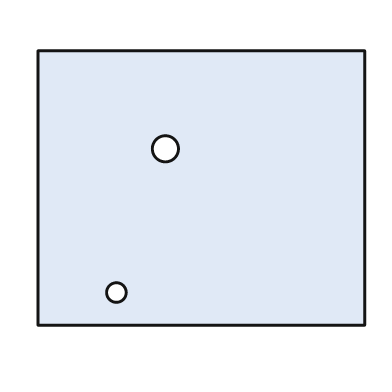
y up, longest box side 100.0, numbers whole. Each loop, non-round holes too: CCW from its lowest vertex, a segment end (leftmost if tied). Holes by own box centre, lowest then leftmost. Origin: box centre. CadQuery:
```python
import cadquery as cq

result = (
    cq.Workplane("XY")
    .moveTo(-50.0, -42.0)
    .lineTo(50.0, -42.0)
    .lineTo(50.0, 42.0)
    .lineTo(-50.0, 42.0)
    .close()
    .moveTo(-26.0, -32.0)
    .circle(3.0)
    .moveTo(-11.0, 12.0)
    .circle(4.0)
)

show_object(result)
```